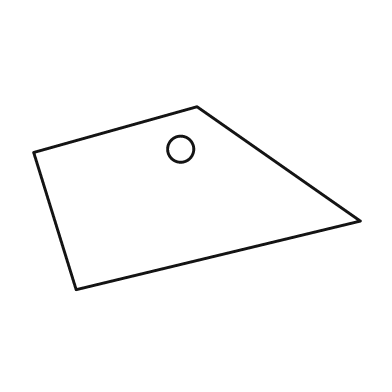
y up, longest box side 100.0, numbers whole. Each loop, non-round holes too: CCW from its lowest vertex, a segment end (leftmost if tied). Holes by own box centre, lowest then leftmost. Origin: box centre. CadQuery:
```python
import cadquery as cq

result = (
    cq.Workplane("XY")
    .moveTo(-37.0, -28.0)
    .lineTo(50.0, -7.0)
    .lineTo(0.0, 28.0)
    .lineTo(-50.0, 14.0)
    .close()
    .moveTo(-5.0, 15.0)
    .circle(4.0)
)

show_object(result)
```